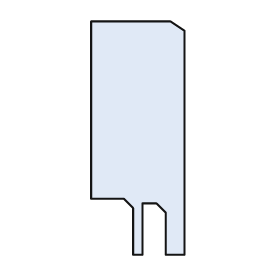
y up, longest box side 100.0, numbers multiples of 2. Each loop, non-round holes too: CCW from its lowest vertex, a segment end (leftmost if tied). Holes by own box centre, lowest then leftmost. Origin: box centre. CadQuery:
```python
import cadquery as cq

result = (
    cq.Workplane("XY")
    .moveTo(-2.0, -50.0)
    .lineTo(2.0, -50.0)
    .lineTo(2.0, -28.0)
    .lineTo(8.0, -28.0)
    .lineTo(12.0, -32.0)
    .lineTo(12.0, -50.0)
    .lineTo(20.0, -50.0)
    .lineTo(20.0, 46.0)
    .lineTo(14.0, 50.0)
    .lineTo(-20.0, 50.0)
    .lineTo(-20.0, -26.0)
    .lineTo(-6.0, -26.0)
    .lineTo(-2.0, -30.0)
    .close()
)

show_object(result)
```